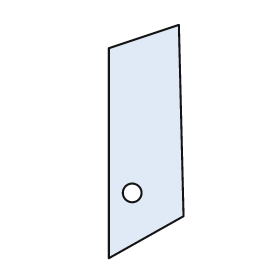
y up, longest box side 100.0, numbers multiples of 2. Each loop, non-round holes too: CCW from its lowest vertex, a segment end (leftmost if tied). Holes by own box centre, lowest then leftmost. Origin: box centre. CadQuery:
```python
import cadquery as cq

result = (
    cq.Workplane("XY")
    .moveTo(-16.0, -50.0)
    .lineTo(16.0, -32.0)
    .lineTo(14.0, 50.0)
    .lineTo(-16.0, 40.0)
    .close()
    .moveTo(-6.0, -22.0)
    .circle(4.0)
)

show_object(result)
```